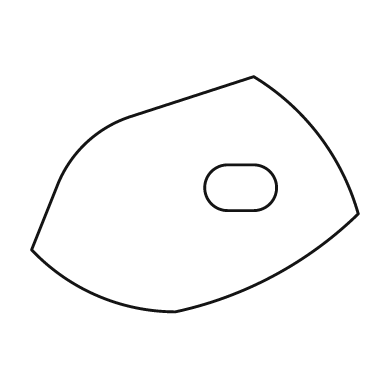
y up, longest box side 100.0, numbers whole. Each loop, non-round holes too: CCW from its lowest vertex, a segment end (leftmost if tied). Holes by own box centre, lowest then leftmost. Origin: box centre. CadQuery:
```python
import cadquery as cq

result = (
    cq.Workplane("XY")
    .moveTo(-6.0, -36.0)
    .threePointArc((24.0, -25.0), (50.0, -6.0))
    .threePointArc((38.0, 18.0), (18.0, 36.0))
    .lineTo(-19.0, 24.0)
    .threePointArc((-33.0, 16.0), (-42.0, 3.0))
    .lineTo(-50.0, -17.0)
    .threePointArc((-30.0, -31.0), (-6.0, -36.0))
    .close()
    .moveTo(10.0, -5.0)
    .lineTo(18.0, -5.0)
    .threePointArc((25.0, 2.0), (18.0, 9.0))
    .lineTo(10.0, 9.0)
    .threePointArc((3.0, 2.0), (10.0, -5.0))
    .close()
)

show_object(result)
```